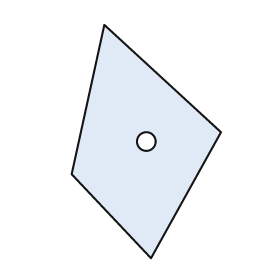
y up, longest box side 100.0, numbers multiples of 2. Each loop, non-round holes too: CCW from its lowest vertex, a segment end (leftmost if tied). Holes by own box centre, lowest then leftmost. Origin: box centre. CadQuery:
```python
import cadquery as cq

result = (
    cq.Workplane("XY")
    .moveTo(2.0, -50.0)
    .lineTo(32.0, 4.0)
    .lineTo(-18.0, 50.0)
    .lineTo(-32.0, -14.0)
    .close()
    .moveTo(0.0, 0.0)
    .circle(4.0)
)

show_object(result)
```